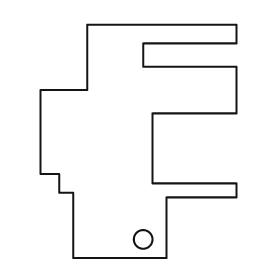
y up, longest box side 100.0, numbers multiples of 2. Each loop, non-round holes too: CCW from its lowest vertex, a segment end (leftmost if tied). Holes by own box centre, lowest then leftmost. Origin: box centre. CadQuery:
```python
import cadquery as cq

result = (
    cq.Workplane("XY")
    .moveTo(-28.0, -50.0)
    .lineTo(12.0, -50.0)
    .lineTo(12.0, -24.0)
    .lineTo(42.0, -24.0)
    .lineTo(42.0, -18.0)
    .lineTo(6.0, -18.0)
    .lineTo(6.0, 12.0)
    .lineTo(42.0, 12.0)
    .lineTo(42.0, 32.0)
    .lineTo(2.0, 32.0)
    .lineTo(2.0, 42.0)
    .lineTo(42.0, 42.0)
    .lineTo(42.0, 50.0)
    .lineTo(-22.0, 50.0)
    .lineTo(-22.0, 22.0)
    .lineTo(-42.0, 22.0)
    .lineTo(-42.0, -14.0)
    .lineTo(-34.0, -14.0)
    .lineTo(-34.0, -22.0)
    .lineTo(-28.0, -22.0)
    .close()
    .moveTo(2.0, -42.0)
    .circle(4.0)
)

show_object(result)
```